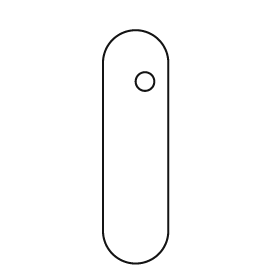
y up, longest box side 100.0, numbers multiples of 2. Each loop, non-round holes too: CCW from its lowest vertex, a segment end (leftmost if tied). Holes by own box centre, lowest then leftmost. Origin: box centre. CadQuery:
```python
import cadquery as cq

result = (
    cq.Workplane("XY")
    .moveTo(-14.0, -36.0)
    .threePointArc((0.0, -50.0), (14.0, -36.0))
    .lineTo(14.0, 36.0)
    .threePointArc((0.0, 50.0), (-14.0, 36.0))
    .close()
    .moveTo(4.0, 28.0)
    .circle(4.0)
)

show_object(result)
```